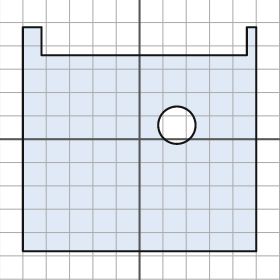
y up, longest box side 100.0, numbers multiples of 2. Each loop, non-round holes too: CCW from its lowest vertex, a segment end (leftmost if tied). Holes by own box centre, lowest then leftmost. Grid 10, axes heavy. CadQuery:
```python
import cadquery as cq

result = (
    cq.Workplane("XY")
    .moveTo(-50.0, -48.0)
    .lineTo(50.0, -48.0)
    .lineTo(50.0, 48.0)
    .lineTo(46.0, 48.0)
    .lineTo(46.0, 36.0)
    .lineTo(-42.0, 36.0)
    .lineTo(-42.0, 48.0)
    .lineTo(-50.0, 48.0)
    .close()
    .moveTo(16.0, 6.0)
    .circle(8.0)
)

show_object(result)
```